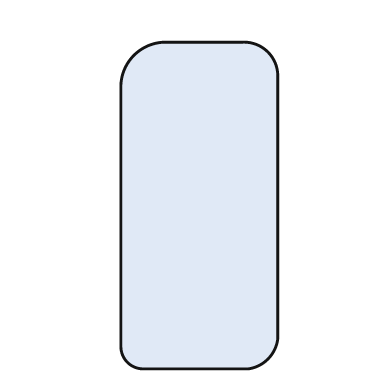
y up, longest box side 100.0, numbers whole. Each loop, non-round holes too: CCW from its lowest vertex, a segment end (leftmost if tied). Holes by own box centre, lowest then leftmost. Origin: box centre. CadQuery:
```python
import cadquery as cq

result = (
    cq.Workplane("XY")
    .moveTo(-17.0, -50.0)
    .lineTo(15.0, -50.0)
    .threePointArc((21.0, -47.0), (24.0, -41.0))
    .lineTo(24.0, 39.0)
    .threePointArc((21.0, 47.0), (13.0, 50.0))
    .lineTo(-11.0, 50.0)
    .threePointArc((-20.0, 46.0), (-24.0, 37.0))
    .lineTo(-24.0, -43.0)
    .threePointArc((-22.0, -48.0), (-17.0, -50.0))
    .close()
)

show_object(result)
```